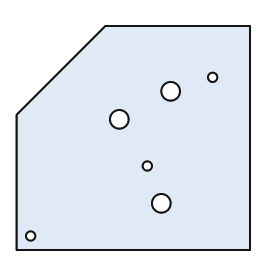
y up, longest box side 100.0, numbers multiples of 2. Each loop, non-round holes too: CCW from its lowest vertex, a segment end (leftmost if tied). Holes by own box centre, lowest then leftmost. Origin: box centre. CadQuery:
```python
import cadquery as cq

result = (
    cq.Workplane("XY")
    .moveTo(-50.0, -48.0)
    .lineTo(50.0, -48.0)
    .lineTo(50.0, 48.0)
    .lineTo(-12.0, 48.0)
    .lineTo(-50.0, 10.0)
    .close()
    .moveTo(-44.0, -42.0)
    .circle(2.0)
    .moveTo(12.0, -28.0)
    .circle(4.0)
    .moveTo(6.0, -12.0)
    .circle(2.0)
    .moveTo(-6.0, 8.0)
    .circle(4.0)
    .moveTo(16.0, 20.0)
    .circle(4.0)
    .moveTo(34.0, 26.0)
    .circle(2.0)
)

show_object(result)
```